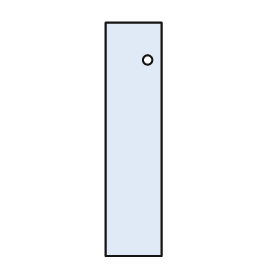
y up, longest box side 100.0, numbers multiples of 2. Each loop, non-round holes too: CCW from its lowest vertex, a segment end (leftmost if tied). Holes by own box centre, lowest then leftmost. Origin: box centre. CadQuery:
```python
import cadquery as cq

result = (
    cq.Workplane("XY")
    .moveTo(-12.0, -50.0)
    .lineTo(12.0, -50.0)
    .lineTo(12.0, 50.0)
    .lineTo(-12.0, 50.0)
    .close()
    .moveTo(6.0, 34.0)
    .circle(2.0)
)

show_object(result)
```